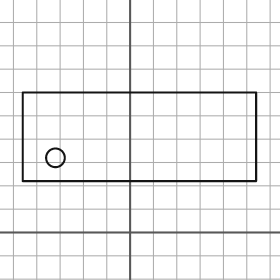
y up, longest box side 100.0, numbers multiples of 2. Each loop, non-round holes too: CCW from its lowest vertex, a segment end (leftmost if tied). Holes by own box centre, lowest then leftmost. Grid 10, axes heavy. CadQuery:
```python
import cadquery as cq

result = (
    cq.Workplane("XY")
    .moveTo(-46.0, 22.0)
    .lineTo(54.0, 22.0)
    .lineTo(54.0, 60.0)
    .lineTo(-46.0, 60.0)
    .close()
    .moveTo(-32.0, 32.0)
    .circle(4.0)
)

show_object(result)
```